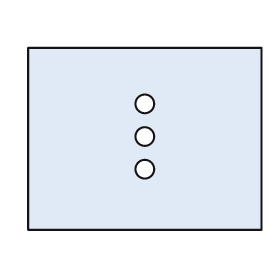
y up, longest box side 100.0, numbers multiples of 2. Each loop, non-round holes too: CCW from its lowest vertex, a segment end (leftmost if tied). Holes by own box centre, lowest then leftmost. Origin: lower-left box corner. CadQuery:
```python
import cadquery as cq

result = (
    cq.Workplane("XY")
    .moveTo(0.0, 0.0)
    .lineTo(100.0, 0.0)
    .lineTo(100.0, 78.0)
    .lineTo(0.0, 78.0)
    .close()
    .moveTo(50.0, 26.0)
    .circle(4.0)
    .moveTo(50.0, 40.0)
    .circle(4.0)
    .moveTo(50.0, 54.0)
    .circle(4.0)
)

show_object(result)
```